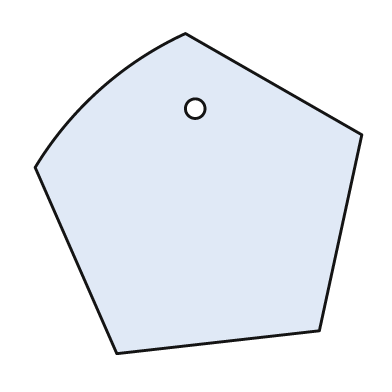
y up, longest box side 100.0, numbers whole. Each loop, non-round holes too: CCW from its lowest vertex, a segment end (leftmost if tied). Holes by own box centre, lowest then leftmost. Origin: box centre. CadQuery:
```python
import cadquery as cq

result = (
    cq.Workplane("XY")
    .moveTo(-25.0, -49.0)
    .lineTo(37.0, -42.0)
    .lineTo(50.0, 18.0)
    .lineTo(-4.0, 49.0)
    .threePointArc((-30.0, 32.0), (-50.0, 8.0))
    .close()
    .moveTo(-1.0, 26.0)
    .circle(3.0)
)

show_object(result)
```